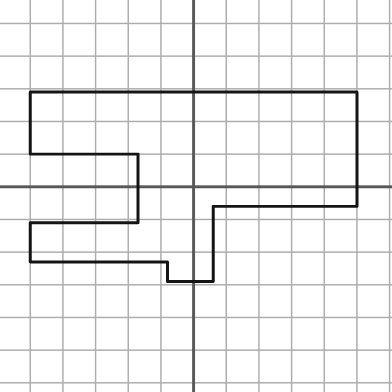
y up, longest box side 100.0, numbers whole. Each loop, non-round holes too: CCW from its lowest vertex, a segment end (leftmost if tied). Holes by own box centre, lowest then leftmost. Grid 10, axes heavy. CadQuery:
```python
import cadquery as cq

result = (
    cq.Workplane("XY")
    .moveTo(-8.0, -29.0)
    .lineTo(6.0, -29.0)
    .lineTo(6.0, -6.0)
    .lineTo(50.0, -6.0)
    .lineTo(50.0, 29.0)
    .lineTo(-50.0, 29.0)
    .lineTo(-50.0, 10.0)
    .lineTo(-17.0, 10.0)
    .lineTo(-17.0, -11.0)
    .lineTo(-50.0, -11.0)
    .lineTo(-50.0, -23.0)
    .lineTo(-8.0, -23.0)
    .close()
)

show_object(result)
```